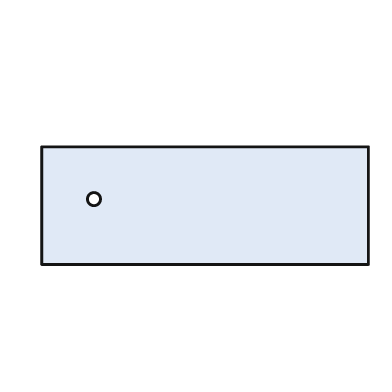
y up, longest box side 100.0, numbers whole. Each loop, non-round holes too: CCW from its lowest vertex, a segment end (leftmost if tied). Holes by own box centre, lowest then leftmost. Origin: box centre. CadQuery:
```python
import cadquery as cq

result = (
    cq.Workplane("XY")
    .moveTo(-50.0, -18.0)
    .lineTo(50.0, -18.0)
    .lineTo(50.0, 18.0)
    .lineTo(-50.0, 18.0)
    .close()
    .moveTo(-34.0, 2.0)
    .circle(2.0)
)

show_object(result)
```